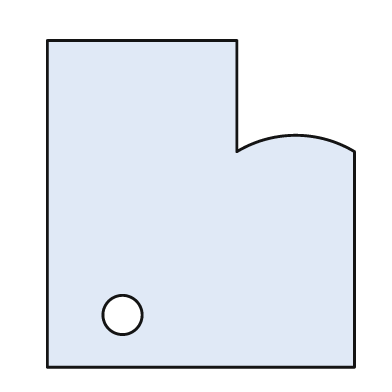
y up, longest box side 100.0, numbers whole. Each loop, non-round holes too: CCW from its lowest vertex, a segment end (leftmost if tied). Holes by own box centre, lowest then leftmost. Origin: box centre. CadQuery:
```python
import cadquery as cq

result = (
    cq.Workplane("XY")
    .moveTo(-47.0, -50.0)
    .lineTo(47.0, -50.0)
    .lineTo(47.0, 16.0)
    .threePointArc((29.0, 21.0), (11.0, 16.0))
    .lineTo(11.0, 50.0)
    .lineTo(-47.0, 50.0)
    .close()
    .moveTo(-24.0, -34.0)
    .circle(6.0)
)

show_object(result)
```